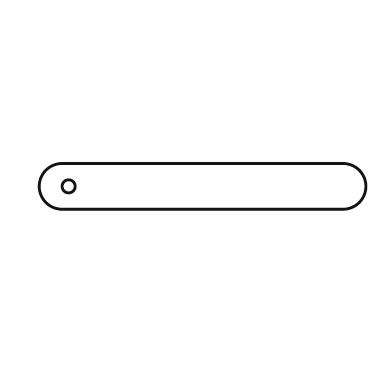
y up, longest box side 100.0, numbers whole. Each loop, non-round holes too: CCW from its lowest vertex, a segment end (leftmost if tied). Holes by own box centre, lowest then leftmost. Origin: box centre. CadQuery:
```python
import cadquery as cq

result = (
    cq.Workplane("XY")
    .moveTo(-43.0, -7.0)
    .lineTo(43.0, -7.0)
    .threePointArc((50.0, 0.0), (43.0, 7.0))
    .lineTo(-43.0, 7.0)
    .threePointArc((-50.0, 0.0), (-43.0, -7.0))
    .close()
    .moveTo(-41.0, 0.0)
    .circle(2.0)
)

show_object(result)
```